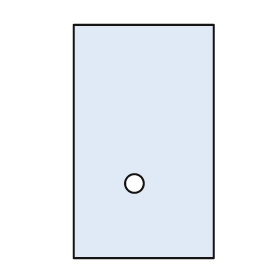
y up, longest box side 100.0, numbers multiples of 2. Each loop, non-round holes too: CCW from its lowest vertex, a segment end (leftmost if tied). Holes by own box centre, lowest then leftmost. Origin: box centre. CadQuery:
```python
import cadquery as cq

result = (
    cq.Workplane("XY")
    .moveTo(-30.0, -50.0)
    .lineTo(30.0, -50.0)
    .lineTo(30.0, 50.0)
    .lineTo(-30.0, 50.0)
    .close()
    .moveTo(-4.0, -18.0)
    .circle(4.0)
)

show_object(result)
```